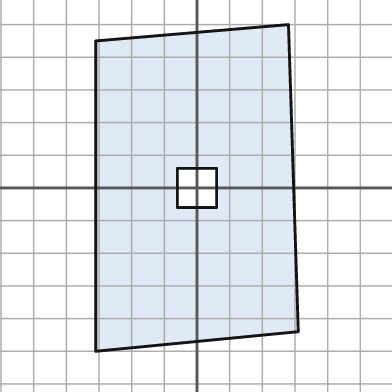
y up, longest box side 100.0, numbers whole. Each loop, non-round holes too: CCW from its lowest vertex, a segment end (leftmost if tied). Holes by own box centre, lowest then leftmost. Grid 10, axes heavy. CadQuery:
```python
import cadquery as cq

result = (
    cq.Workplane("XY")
    .moveTo(-31.0, -50.0)
    .lineTo(31.0, -44.0)
    .lineTo(28.0, 50.0)
    .lineTo(-31.0, 45.0)
    .close()
    .moveTo(-6.0, -6.0)
    .lineTo(6.0, -6.0)
    .lineTo(6.0, 6.0)
    .lineTo(-6.0, 6.0)
    .close()
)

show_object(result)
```